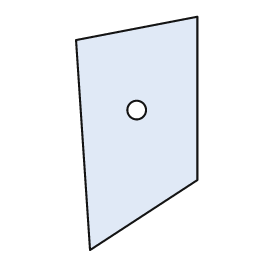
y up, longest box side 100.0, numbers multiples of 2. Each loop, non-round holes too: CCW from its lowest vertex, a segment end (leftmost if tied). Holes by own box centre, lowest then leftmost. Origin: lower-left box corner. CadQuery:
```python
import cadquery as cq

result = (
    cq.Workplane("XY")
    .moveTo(6.0, 0.0)
    .lineTo(52.0, 30.0)
    .lineTo(52.0, 100.0)
    .lineTo(0.0, 90.0)
    .close()
    .moveTo(26.0, 60.0)
    .circle(4.0)
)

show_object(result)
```